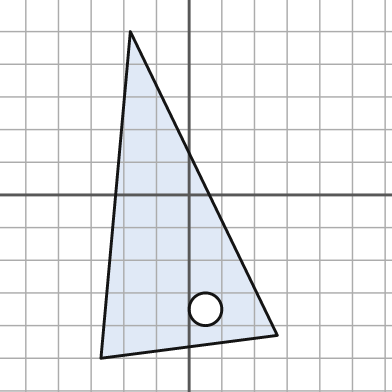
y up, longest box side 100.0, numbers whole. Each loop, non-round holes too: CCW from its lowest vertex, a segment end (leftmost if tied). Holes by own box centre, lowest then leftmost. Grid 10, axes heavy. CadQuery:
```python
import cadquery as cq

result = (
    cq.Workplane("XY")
    .moveTo(-27.0, -50.0)
    .lineTo(27.0, -43.0)
    .lineTo(-18.0, 50.0)
    .close()
    .moveTo(5.0, -35.0)
    .circle(5.0)
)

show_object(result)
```